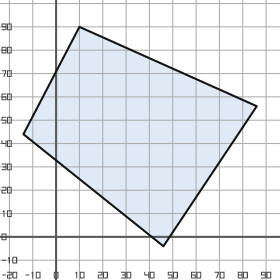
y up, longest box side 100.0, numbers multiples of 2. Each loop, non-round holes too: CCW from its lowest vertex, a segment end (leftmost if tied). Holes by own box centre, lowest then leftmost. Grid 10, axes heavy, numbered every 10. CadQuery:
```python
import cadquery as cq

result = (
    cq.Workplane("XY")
    .moveTo(46.0, -4.0)
    .lineTo(86.0, 56.0)
    .lineTo(10.0, 90.0)
    .lineTo(-14.0, 44.0)
    .close()
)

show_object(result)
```